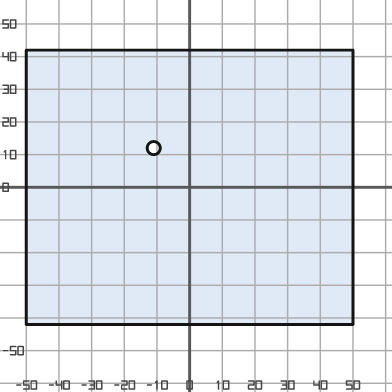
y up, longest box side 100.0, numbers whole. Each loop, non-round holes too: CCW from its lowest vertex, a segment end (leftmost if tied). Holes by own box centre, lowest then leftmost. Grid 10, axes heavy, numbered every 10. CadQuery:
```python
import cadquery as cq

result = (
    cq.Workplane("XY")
    .moveTo(-50.0, -42.0)
    .lineTo(50.0, -42.0)
    .lineTo(50.0, 42.0)
    .lineTo(-50.0, 42.0)
    .close()
    .moveTo(-11.0, 12.0)
    .circle(2.0)
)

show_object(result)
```